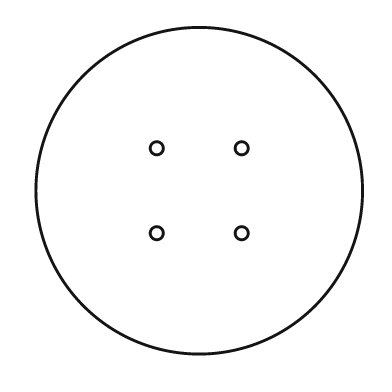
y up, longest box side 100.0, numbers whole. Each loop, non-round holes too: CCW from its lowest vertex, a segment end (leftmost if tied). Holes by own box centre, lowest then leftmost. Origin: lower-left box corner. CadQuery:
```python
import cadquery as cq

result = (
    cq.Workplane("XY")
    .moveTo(50.0, 50.0)
    .circle(50.0)
    .moveTo(37.0, 37.0)
    .circle(2.0)
    .moveTo(63.0, 37.0)
    .circle(2.0)
    .moveTo(37.0, 63.0)
    .circle(2.0)
    .moveTo(63.0, 63.0)
    .circle(2.0)
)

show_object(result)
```